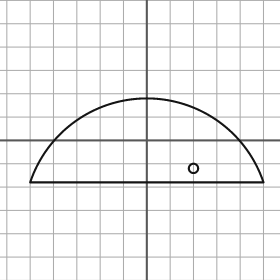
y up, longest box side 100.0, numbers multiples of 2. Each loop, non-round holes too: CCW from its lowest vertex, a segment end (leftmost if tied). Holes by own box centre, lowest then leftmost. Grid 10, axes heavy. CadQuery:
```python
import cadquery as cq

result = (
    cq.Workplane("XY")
    .moveTo(-50.0, -18.0)
    .lineTo(50.0, -18.0)
    .threePointArc((0.0, 18.0), (-50.0, -18.0))
    .close()
    .moveTo(20.0, -12.0)
    .circle(2.0)
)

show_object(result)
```